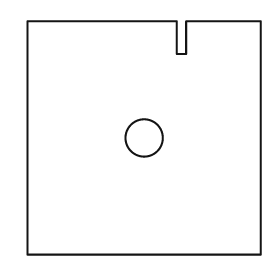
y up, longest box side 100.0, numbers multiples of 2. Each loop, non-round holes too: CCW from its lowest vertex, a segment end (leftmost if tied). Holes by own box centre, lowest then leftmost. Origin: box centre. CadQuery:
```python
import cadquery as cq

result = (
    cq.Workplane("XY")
    .moveTo(-50.0, -50.0)
    .lineTo(50.0, -50.0)
    .lineTo(50.0, 50.0)
    .lineTo(18.0, 50.0)
    .lineTo(18.0, 36.0)
    .lineTo(14.0, 36.0)
    .lineTo(14.0, 50.0)
    .lineTo(-50.0, 50.0)
    .close()
    .moveTo(0.0, 0.0)
    .circle(8.0)
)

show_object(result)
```